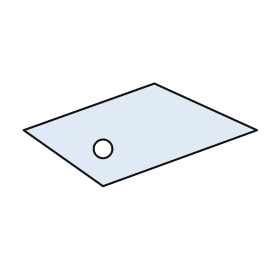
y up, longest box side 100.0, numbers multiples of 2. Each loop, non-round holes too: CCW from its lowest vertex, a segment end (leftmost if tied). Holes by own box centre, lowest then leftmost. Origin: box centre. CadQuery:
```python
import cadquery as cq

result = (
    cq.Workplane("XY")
    .moveTo(-16.0, -22.0)
    .lineTo(50.0, 2.0)
    .lineTo(6.0, 22.0)
    .lineTo(-50.0, 2.0)
    .close()
    .moveTo(-16.0, -6.0)
    .circle(4.0)
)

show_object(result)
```